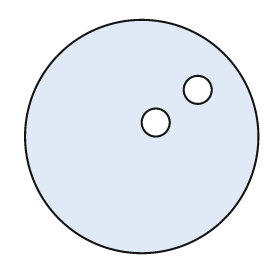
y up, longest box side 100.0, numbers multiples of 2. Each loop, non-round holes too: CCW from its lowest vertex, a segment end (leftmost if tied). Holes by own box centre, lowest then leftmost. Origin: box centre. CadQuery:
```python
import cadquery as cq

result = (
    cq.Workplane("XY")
    .moveTo(0.0, 0.0)
    .circle(50.0)
    .moveTo(6.0, 6.0)
    .circle(6.0)
    .moveTo(24.0, 20.0)
    .circle(6.0)
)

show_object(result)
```